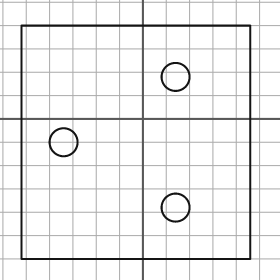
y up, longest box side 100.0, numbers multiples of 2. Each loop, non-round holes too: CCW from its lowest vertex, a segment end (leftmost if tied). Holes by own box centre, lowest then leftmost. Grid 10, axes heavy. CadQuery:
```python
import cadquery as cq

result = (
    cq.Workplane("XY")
    .moveTo(-52.0, -60.0)
    .lineTo(46.0, -60.0)
    .lineTo(46.0, 40.0)
    .lineTo(-52.0, 40.0)
    .close()
    .moveTo(14.0, -38.0)
    .circle(6.0)
    .moveTo(-34.0, -10.0)
    .circle(6.0)
    .moveTo(14.0, 18.0)
    .circle(6.0)
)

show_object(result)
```